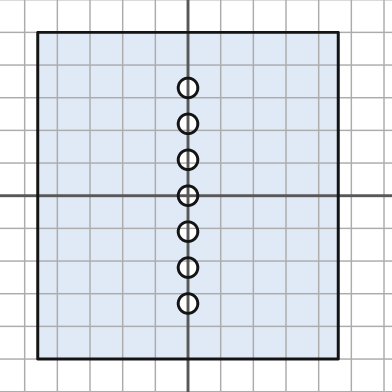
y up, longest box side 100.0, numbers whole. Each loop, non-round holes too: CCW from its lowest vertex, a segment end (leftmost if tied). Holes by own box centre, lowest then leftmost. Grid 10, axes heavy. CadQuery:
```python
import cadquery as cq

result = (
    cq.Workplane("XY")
    .moveTo(-46.0, -50.0)
    .lineTo(46.0, -50.0)
    .lineTo(46.0, 50.0)
    .lineTo(-46.0, 50.0)
    .close()
    .moveTo(0.0, -33.0)
    .circle(3.0)
    .moveTo(0.0, -22.0)
    .circle(3.0)
    .moveTo(0.0, -11.0)
    .circle(3.0)
    .moveTo(0.0, 0.0)
    .circle(3.0)
    .moveTo(0.0, 11.0)
    .circle(3.0)
    .moveTo(0.0, 22.0)
    .circle(3.0)
    .moveTo(0.0, 33.0)
    .circle(3.0)
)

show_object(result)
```